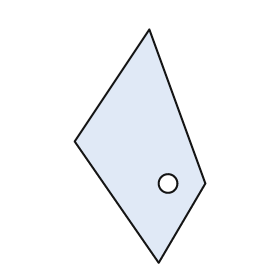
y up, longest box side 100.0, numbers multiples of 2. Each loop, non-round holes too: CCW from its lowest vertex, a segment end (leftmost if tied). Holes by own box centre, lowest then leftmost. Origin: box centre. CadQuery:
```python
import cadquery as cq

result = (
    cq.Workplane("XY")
    .moveTo(8.0, -50.0)
    .lineTo(28.0, -16.0)
    .lineTo(4.0, 50.0)
    .lineTo(-28.0, 2.0)
    .close()
    .moveTo(12.0, -16.0)
    .circle(4.0)
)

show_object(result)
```